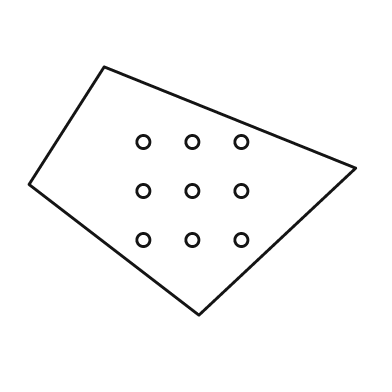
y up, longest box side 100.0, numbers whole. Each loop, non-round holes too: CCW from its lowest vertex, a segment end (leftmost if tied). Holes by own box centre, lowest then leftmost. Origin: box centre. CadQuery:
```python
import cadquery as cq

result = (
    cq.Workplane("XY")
    .moveTo(2.0, -38.0)
    .lineTo(50.0, 7.0)
    .lineTo(-27.0, 38.0)
    .lineTo(-50.0, 2.0)
    .close()
    .moveTo(-15.0, -15.0)
    .circle(2.0)
    .moveTo(0.0, -15.0)
    .circle(2.0)
    .moveTo(15.0, -15.0)
    .circle(2.0)
    .moveTo(-15.0, 0.0)
    .circle(2.0)
    .moveTo(0.0, 0.0)
    .circle(2.0)
    .moveTo(15.0, 0.0)
    .circle(2.0)
    .moveTo(-15.0, 15.0)
    .circle(2.0)
    .moveTo(0.0, 15.0)
    .circle(2.0)
    .moveTo(15.0, 15.0)
    .circle(2.0)
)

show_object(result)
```